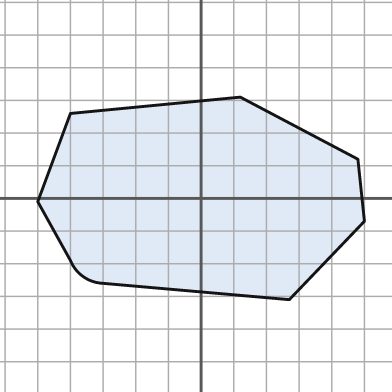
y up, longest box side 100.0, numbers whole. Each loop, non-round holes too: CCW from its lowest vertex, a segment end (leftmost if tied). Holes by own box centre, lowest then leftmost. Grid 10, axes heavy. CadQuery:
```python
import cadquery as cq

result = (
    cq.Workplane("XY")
    .moveTo(27.0, -31.0)
    .lineTo(50.0, -7.0)
    .lineTo(48.0, 12.0)
    .lineTo(12.0, 31.0)
    .lineTo(-40.0, 26.0)
    .lineTo(-50.0, -1.0)
    .lineTo(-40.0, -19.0)
    .threePointArc((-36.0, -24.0), (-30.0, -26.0))
    .close()
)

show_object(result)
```